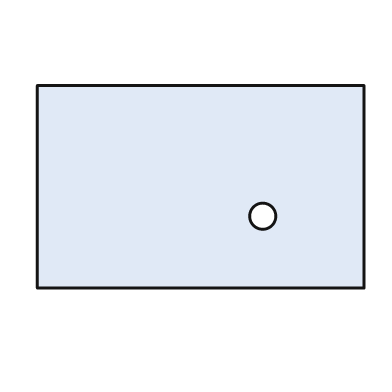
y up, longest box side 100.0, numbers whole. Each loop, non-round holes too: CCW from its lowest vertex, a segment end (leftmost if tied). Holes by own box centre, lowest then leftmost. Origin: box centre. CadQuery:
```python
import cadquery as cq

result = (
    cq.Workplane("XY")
    .moveTo(-50.0, -31.0)
    .lineTo(50.0, -31.0)
    .lineTo(50.0, 31.0)
    .lineTo(-50.0, 31.0)
    .close()
    .moveTo(19.0, -9.0)
    .circle(4.0)
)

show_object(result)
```